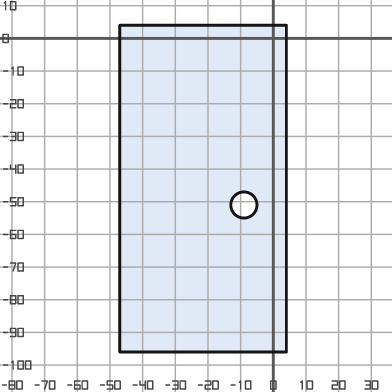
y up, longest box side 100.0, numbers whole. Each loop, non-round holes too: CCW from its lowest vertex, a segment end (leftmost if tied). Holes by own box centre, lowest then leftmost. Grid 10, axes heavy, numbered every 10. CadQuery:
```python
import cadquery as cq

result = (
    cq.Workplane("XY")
    .moveTo(-47.0, -96.0)
    .lineTo(4.0, -96.0)
    .lineTo(4.0, 4.0)
    .lineTo(-47.0, 4.0)
    .close()
    .moveTo(-9.0, -51.0)
    .circle(4.0)
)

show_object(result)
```